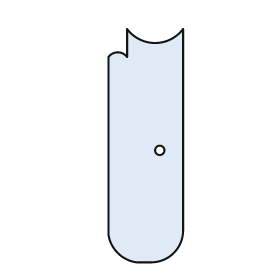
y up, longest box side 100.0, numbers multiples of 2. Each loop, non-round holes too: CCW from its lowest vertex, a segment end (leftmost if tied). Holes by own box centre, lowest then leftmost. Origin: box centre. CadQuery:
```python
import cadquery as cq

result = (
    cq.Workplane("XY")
    .moveTo(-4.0, -50.0)
    .lineTo(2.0, -50.0)
    .threePointArc((12.0, -46.0), (16.0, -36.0))
    .lineTo(16.0, 50.0)
    .threePointArc((4.0, 44.0), (-8.0, 50.0))
    .lineTo(-8.0, 38.0)
    .threePointArc((-12.0, 40.0), (-16.0, 38.0))
    .lineTo(-16.0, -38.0)
    .threePointArc((-12.0, -46.0), (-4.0, -50.0))
    .close()
    .moveTo(6.0, -2.0)
    .circle(2.0)
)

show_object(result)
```